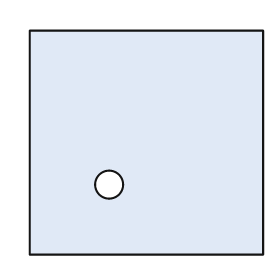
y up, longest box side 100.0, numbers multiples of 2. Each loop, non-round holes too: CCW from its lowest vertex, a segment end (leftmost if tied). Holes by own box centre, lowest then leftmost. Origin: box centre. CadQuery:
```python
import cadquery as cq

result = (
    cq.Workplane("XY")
    .moveTo(-50.0, -48.0)
    .lineTo(50.0, -48.0)
    .lineTo(50.0, 48.0)
    .lineTo(-50.0, 48.0)
    .close()
    .moveTo(-16.0, -18.0)
    .circle(6.0)
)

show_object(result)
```